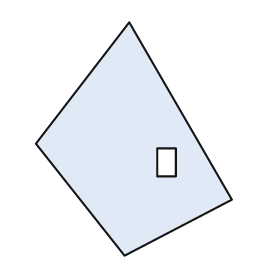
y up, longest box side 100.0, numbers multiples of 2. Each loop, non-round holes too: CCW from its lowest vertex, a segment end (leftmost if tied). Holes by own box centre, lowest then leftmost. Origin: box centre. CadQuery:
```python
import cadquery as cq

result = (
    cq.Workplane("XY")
    .moveTo(-4.0, -50.0)
    .lineTo(42.0, -26.0)
    .lineTo(-2.0, 50.0)
    .lineTo(-42.0, -2.0)
    .close()
    .moveTo(10.0, -16.0)
    .lineTo(18.0, -16.0)
    .lineTo(18.0, -4.0)
    .lineTo(10.0, -4.0)
    .close()
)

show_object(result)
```